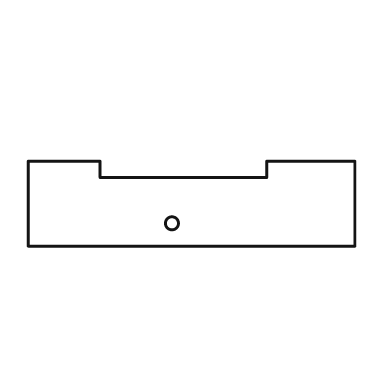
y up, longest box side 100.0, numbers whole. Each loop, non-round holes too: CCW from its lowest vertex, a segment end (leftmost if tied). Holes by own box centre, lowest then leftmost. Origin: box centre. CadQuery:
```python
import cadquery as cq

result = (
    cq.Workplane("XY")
    .moveTo(-50.0, -13.0)
    .lineTo(50.0, -13.0)
    .lineTo(50.0, 13.0)
    .lineTo(23.0, 13.0)
    .lineTo(23.0, 8.0)
    .lineTo(-28.0, 8.0)
    .lineTo(-28.0, 13.0)
    .lineTo(-50.0, 13.0)
    .close()
    .moveTo(-6.0, -6.0)
    .circle(2.0)
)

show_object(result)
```